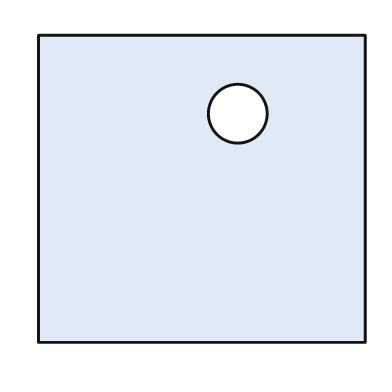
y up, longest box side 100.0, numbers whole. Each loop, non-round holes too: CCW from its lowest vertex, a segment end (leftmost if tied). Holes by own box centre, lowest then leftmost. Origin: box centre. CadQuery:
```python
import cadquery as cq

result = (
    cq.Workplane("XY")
    .moveTo(-50.0, -47.0)
    .lineTo(50.0, -47.0)
    .lineTo(50.0, 47.0)
    .lineTo(-50.0, 47.0)
    .close()
    .moveTo(11.0, 23.0)
    .circle(9.0)
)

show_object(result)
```